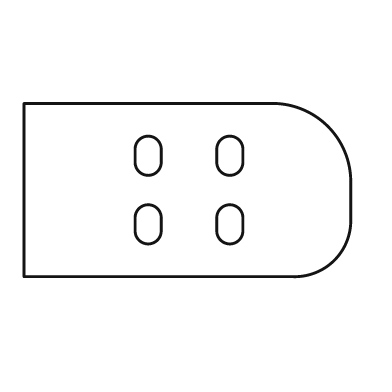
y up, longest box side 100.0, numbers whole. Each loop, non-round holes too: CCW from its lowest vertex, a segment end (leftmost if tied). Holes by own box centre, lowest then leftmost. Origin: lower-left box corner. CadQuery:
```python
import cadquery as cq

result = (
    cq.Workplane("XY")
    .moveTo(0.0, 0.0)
    .lineTo(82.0, 0.0)
    .threePointArc((95.0, 5.0), (100.0, 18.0))
    .lineTo(100.0, 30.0)
    .threePointArc((93.0, 46.0), (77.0, 53.0))
    .lineTo(0.0, 53.0)
    .close()
    .moveTo(34.0, 14.0)
    .threePointArc((38.0, 10.0), (42.0, 14.0))
    .lineTo(42.0, 18.0)
    .threePointArc((38.0, 22.0), (34.0, 18.0))
    .close()
    .moveTo(59.0, 14.0)
    .threePointArc((63.0, 10.0), (67.0, 14.0))
    .lineTo(67.0, 18.0)
    .threePointArc((63.0, 22.0), (59.0, 18.0))
    .close()
    .moveTo(34.0, 35.0)
    .threePointArc((38.0, 31.0), (42.0, 35.0))
    .lineTo(42.0, 39.0)
    .threePointArc((38.0, 43.0), (34.0, 39.0))
    .close()
    .moveTo(59.0, 35.0)
    .threePointArc((63.0, 31.0), (67.0, 35.0))
    .lineTo(67.0, 39.0)
    .threePointArc((63.0, 43.0), (59.0, 39.0))
    .close()
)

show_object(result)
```